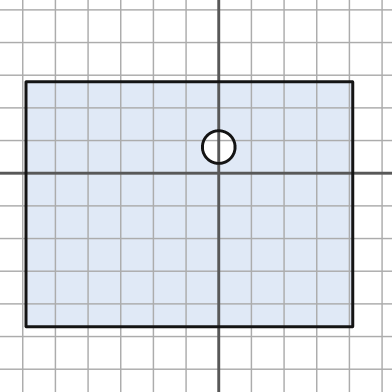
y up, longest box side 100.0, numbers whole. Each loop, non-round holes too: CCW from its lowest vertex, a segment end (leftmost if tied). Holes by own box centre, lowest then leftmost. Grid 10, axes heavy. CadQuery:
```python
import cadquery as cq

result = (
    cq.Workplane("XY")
    .moveTo(-59.0, -47.0)
    .lineTo(41.0, -47.0)
    .lineTo(41.0, 28.0)
    .lineTo(-59.0, 28.0)
    .close()
    .moveTo(0.0, 8.0)
    .circle(5.0)
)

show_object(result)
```